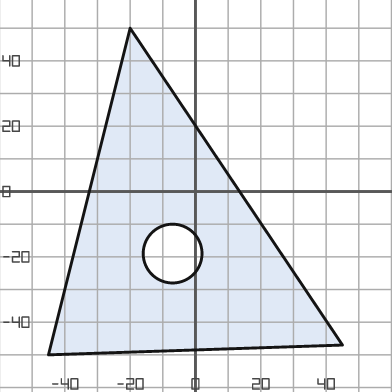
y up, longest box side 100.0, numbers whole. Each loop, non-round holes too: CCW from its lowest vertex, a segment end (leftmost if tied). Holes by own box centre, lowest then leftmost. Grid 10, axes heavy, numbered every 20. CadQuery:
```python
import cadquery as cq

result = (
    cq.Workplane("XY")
    .moveTo(-45.0, -50.0)
    .lineTo(45.0, -47.0)
    .lineTo(-20.0, 50.0)
    .close()
    .moveTo(-7.0, -19.0)
    .circle(9.0)
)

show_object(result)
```